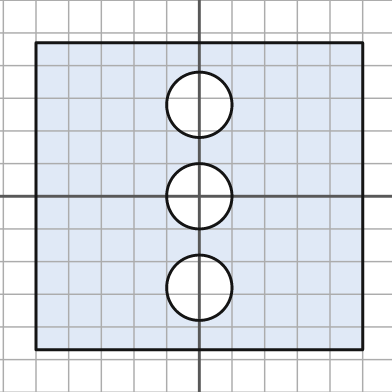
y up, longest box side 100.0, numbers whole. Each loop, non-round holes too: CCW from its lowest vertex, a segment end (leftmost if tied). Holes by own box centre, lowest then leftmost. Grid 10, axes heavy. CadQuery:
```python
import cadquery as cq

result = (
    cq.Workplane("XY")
    .moveTo(-50.0, -47.0)
    .lineTo(50.0, -47.0)
    .lineTo(50.0, 47.0)
    .lineTo(-50.0, 47.0)
    .close()
    .moveTo(0.0, -28.0)
    .circle(10.0)
    .moveTo(0.0, 0.0)
    .circle(10.0)
    .moveTo(0.0, 28.0)
    .circle(10.0)
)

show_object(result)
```